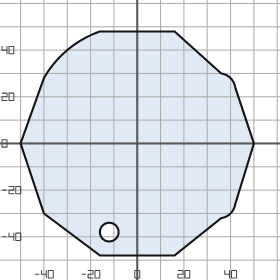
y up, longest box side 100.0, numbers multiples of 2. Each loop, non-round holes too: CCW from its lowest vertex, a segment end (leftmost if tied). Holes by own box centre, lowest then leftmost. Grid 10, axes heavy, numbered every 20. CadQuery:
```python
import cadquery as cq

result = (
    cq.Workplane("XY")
    .moveTo(-16.0, -48.0)
    .lineTo(16.0, -48.0)
    .lineTo(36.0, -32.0)
    .threePointArc((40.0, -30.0), (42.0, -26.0))
    .lineTo(50.0, 0.0)
    .lineTo(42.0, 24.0)
    .threePointArc((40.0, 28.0), (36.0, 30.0))
    .lineTo(16.0, 48.0)
    .lineTo(-16.0, 48.0)
    .threePointArc((-30.0, 40.0), (-40.0, 28.0))
    .lineTo(-50.0, 0.0)
    .lineTo(-40.0, -30.0)
    .close()
    .moveTo(-12.0, -38.0)
    .circle(4.0)
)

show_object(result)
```